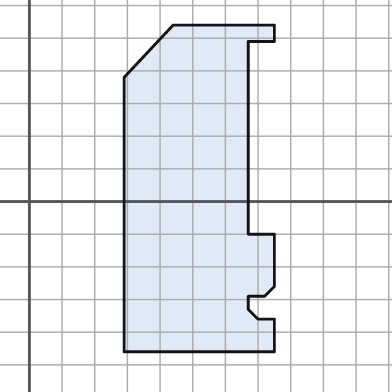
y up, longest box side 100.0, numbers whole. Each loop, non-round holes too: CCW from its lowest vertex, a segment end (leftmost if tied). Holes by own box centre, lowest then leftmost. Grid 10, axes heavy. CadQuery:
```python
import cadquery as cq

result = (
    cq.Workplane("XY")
    .moveTo(29.0, -46.0)
    .lineTo(75.0, -46.0)
    .lineTo(75.0, -36.0)
    .lineTo(70.0, -36.0)
    .lineTo(67.0, -33.0)
    .lineTo(67.0, -29.0)
    .lineTo(72.0, -29.0)
    .lineTo(75.0, -26.0)
    .lineTo(75.0, -10.0)
    .lineTo(67.0, -10.0)
    .lineTo(67.0, 49.0)
    .lineTo(75.0, 49.0)
    .lineTo(75.0, 54.0)
    .lineTo(44.0, 54.0)
    .lineTo(29.0, 38.0)
    .close()
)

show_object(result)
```